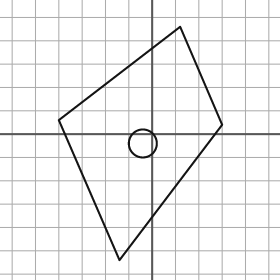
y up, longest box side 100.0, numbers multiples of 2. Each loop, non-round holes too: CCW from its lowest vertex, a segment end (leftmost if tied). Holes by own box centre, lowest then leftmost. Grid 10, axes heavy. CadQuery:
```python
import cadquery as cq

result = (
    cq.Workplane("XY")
    .moveTo(-14.0, -54.0)
    .lineTo(30.0, 4.0)
    .lineTo(12.0, 46.0)
    .lineTo(-40.0, 6.0)
    .close()
    .moveTo(-4.0, -4.0)
    .circle(6.0)
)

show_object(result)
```